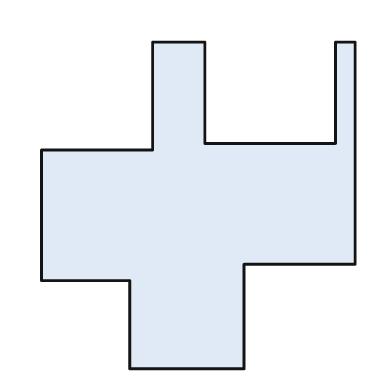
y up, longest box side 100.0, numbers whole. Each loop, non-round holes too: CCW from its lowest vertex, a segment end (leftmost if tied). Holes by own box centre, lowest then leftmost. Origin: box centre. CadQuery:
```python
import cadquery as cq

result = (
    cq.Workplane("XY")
    .moveTo(-21.0, -50.0)
    .lineTo(14.0, -50.0)
    .lineTo(14.0, -18.0)
    .lineTo(48.0, -18.0)
    .lineTo(48.0, 50.0)
    .lineTo(42.0, 50.0)
    .lineTo(42.0, 19.0)
    .lineTo(2.0, 19.0)
    .lineTo(2.0, 50.0)
    .lineTo(-14.0, 50.0)
    .lineTo(-14.0, 17.0)
    .lineTo(-48.0, 17.0)
    .lineTo(-48.0, -23.0)
    .lineTo(-21.0, -23.0)
    .close()
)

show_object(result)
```